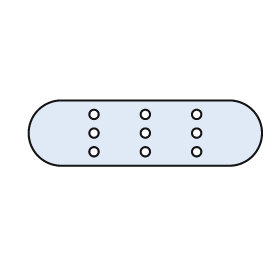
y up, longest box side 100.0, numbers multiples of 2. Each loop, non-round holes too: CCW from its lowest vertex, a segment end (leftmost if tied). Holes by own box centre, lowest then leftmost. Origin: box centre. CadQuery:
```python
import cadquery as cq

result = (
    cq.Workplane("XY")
    .moveTo(-36.0, -14.0)
    .lineTo(36.0, -14.0)
    .threePointArc((50.0, 0.0), (36.0, 14.0))
    .lineTo(-36.0, 14.0)
    .threePointArc((-50.0, 0.0), (-36.0, -14.0))
    .close()
    .moveTo(-22.0, -8.0)
    .circle(2.0)
    .moveTo(0.0, -8.0)
    .circle(2.0)
    .moveTo(22.0, -8.0)
    .circle(2.0)
    .moveTo(-22.0, 0.0)
    .circle(2.0)
    .moveTo(0.0, 0.0)
    .circle(2.0)
    .moveTo(22.0, 0.0)
    .circle(2.0)
    .moveTo(-22.0, 8.0)
    .circle(2.0)
    .moveTo(0.0, 8.0)
    .circle(2.0)
    .moveTo(22.0, 8.0)
    .circle(2.0)
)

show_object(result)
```